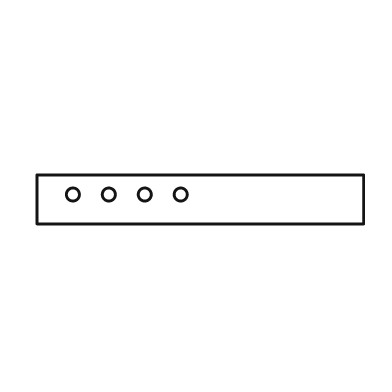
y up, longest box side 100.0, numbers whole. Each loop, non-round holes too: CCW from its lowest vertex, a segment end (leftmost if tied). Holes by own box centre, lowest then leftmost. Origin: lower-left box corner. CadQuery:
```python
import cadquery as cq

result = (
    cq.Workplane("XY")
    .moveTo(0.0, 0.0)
    .lineTo(100.0, 0.0)
    .lineTo(100.0, 15.0)
    .lineTo(0.0, 15.0)
    .close()
    .moveTo(11.0, 9.0)
    .circle(2.0)
    .moveTo(22.0, 9.0)
    .circle(2.0)
    .moveTo(33.0, 9.0)
    .circle(2.0)
    .moveTo(44.0, 9.0)
    .circle(2.0)
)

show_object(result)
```